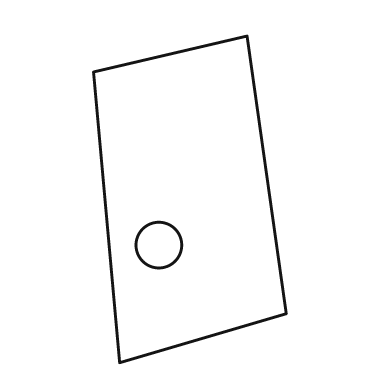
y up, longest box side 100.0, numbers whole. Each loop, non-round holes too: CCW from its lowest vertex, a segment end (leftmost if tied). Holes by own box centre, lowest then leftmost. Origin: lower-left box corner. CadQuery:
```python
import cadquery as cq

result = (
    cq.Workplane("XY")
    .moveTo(8.0, 0.0)
    .lineTo(59.0, 15.0)
    .lineTo(47.0, 100.0)
    .lineTo(0.0, 89.0)
    .close()
    .moveTo(20.0, 36.0)
    .circle(7.0)
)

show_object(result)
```